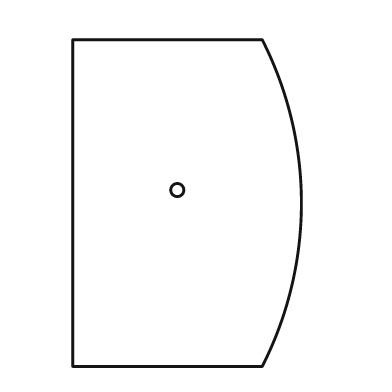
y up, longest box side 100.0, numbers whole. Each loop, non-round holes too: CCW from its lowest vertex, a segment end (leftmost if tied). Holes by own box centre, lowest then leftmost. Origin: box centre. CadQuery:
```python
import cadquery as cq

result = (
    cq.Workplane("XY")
    .moveTo(-35.0, -50.0)
    .lineTo(23.0, -50.0)
    .threePointArc((35.0, 0.0), (23.0, 50.0))
    .lineTo(-35.0, 50.0)
    .close()
    .moveTo(-3.0, 4.0)
    .circle(2.0)
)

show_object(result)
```